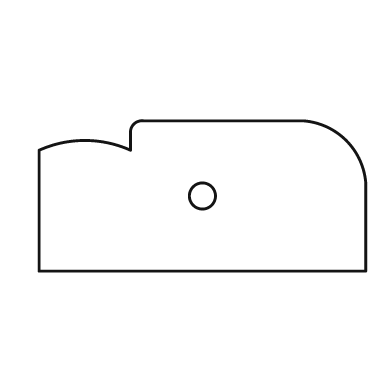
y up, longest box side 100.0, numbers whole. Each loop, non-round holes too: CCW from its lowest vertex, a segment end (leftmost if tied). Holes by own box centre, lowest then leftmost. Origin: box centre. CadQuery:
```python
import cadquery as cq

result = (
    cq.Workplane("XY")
    .moveTo(-50.0, -23.0)
    .lineTo(50.0, -23.0)
    .lineTo(50.0, 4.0)
    .threePointArc((44.0, 17.0), (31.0, 23.0))
    .lineTo(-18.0, 23.0)
    .threePointArc((-21.0, 22.0), (-22.0, 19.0))
    .lineTo(-22.0, 14.0)
    .threePointArc((-36.0, 17.0), (-50.0, 14.0))
    .close()
    .moveTo(0.0, 0.0)
    .circle(4.0)
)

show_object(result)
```